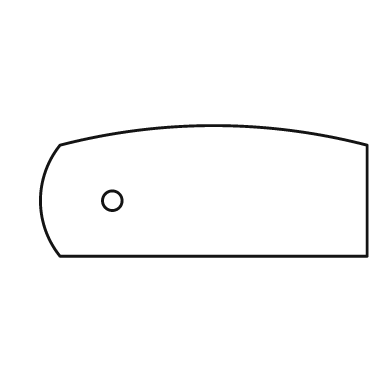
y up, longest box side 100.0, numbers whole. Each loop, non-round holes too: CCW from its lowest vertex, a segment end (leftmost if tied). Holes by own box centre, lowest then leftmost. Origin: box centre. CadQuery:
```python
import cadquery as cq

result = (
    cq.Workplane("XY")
    .moveTo(-44.0, -20.0)
    .lineTo(50.0, -20.0)
    .lineTo(50.0, 14.0)
    .threePointArc((3.0, 20.0), (-44.0, 14.0))
    .threePointArc((-50.0, -3.0), (-44.0, -20.0))
    .close()
    .moveTo(-28.0, -3.0)
    .circle(3.0)
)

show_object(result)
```